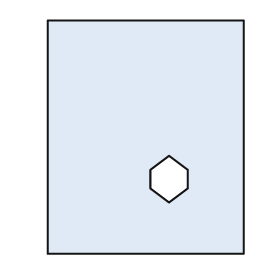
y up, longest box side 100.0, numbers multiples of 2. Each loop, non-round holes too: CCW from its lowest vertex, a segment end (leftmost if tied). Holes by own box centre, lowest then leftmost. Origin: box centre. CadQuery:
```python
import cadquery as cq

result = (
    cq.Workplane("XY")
    .moveTo(-42.0, -50.0)
    .lineTo(42.0, -50.0)
    .lineTo(42.0, 50.0)
    .lineTo(-42.0, 50.0)
    .close()
    .moveTo(10.0, -28.0)
    .lineTo(18.0, -22.0)
    .lineTo(18.0, -14.0)
    .lineTo(10.0, -8.0)
    .lineTo(2.0, -14.0)
    .lineTo(2.0, -22.0)
    .close()
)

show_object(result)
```